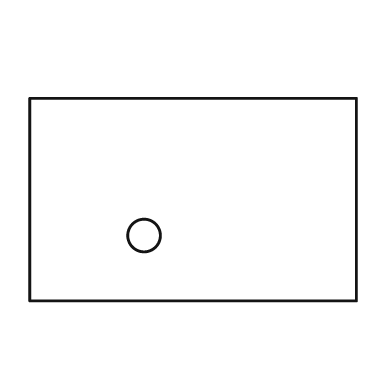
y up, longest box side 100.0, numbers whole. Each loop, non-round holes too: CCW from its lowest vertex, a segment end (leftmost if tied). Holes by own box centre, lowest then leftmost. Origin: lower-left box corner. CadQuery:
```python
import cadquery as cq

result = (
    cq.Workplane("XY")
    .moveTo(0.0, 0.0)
    .lineTo(100.0, 0.0)
    .lineTo(100.0, 62.0)
    .lineTo(0.0, 62.0)
    .close()
    .moveTo(35.0, 20.0)
    .circle(5.0)
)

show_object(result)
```